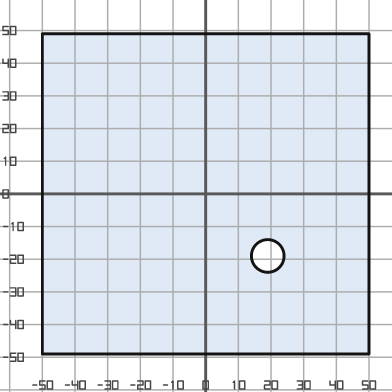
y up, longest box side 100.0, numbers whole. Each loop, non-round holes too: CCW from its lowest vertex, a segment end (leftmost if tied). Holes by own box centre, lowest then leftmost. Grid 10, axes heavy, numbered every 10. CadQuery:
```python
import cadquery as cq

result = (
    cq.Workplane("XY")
    .moveTo(-50.0, -49.0)
    .lineTo(50.0, -49.0)
    .lineTo(50.0, 49.0)
    .lineTo(-50.0, 49.0)
    .close()
    .moveTo(19.0, -19.0)
    .circle(5.0)
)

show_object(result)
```